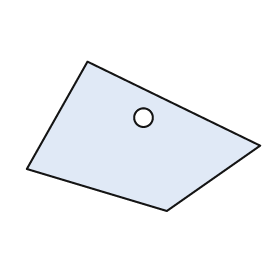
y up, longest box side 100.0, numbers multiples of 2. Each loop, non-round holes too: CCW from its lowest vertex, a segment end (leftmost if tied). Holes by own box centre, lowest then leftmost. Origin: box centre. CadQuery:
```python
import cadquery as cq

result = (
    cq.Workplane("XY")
    .moveTo(10.0, -32.0)
    .lineTo(50.0, -4.0)
    .lineTo(-24.0, 32.0)
    .lineTo(-50.0, -14.0)
    .close()
    .moveTo(0.0, 8.0)
    .circle(4.0)
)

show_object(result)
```